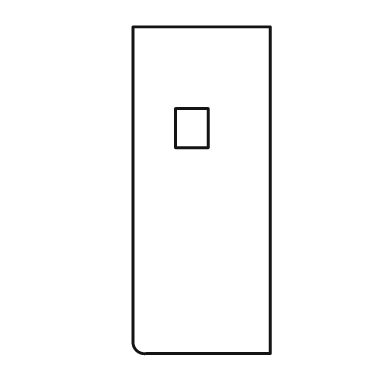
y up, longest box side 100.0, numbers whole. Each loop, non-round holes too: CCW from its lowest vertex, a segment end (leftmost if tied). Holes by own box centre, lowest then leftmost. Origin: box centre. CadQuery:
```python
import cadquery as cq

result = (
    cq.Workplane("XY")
    .moveTo(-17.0, -50.0)
    .lineTo(21.0, -50.0)
    .lineTo(21.0, 50.0)
    .lineTo(-21.0, 50.0)
    .lineTo(-21.0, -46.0)
    .threePointArc((-20.0, -49.0), (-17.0, -50.0))
    .close()
    .moveTo(-8.0, 13.0)
    .lineTo(2.0, 13.0)
    .lineTo(2.0, 25.0)
    .lineTo(-8.0, 25.0)
    .close()
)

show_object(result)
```